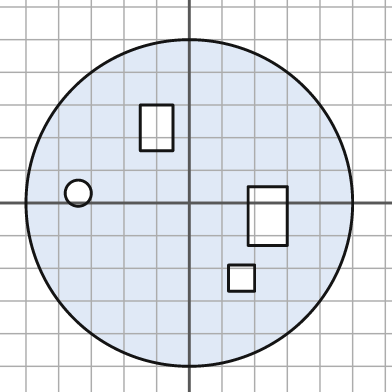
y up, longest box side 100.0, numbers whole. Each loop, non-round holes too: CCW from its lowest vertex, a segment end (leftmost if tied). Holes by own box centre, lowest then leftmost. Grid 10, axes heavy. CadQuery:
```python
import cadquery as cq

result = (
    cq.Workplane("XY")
    .moveTo(0.0, 0.0)
    .circle(50.0)
    .moveTo(12.0, -27.0)
    .lineTo(20.0, -27.0)
    .lineTo(20.0, -19.0)
    .lineTo(12.0, -19.0)
    .close()
    .moveTo(18.0, -13.0)
    .lineTo(30.0, -13.0)
    .lineTo(30.0, 5.0)
    .lineTo(18.0, 5.0)
    .close()
    .moveTo(-34.0, 3.0)
    .circle(4.0)
    .moveTo(-15.0, 16.0)
    .lineTo(-5.0, 16.0)
    .lineTo(-5.0, 30.0)
    .lineTo(-15.0, 30.0)
    .close()
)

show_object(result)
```